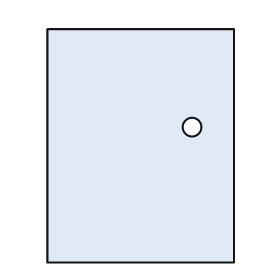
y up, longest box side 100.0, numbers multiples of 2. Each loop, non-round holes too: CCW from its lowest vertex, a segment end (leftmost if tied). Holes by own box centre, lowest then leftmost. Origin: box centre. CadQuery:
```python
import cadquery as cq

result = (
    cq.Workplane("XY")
    .moveTo(-40.0, -50.0)
    .lineTo(40.0, -50.0)
    .lineTo(40.0, 50.0)
    .lineTo(-40.0, 50.0)
    .close()
    .moveTo(22.0, 8.0)
    .circle(4.0)
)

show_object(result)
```